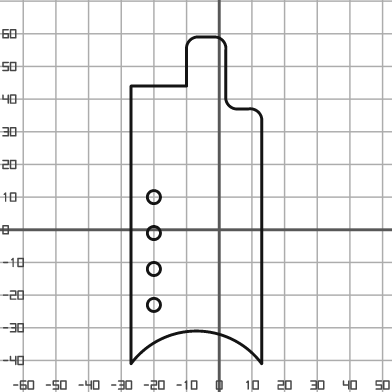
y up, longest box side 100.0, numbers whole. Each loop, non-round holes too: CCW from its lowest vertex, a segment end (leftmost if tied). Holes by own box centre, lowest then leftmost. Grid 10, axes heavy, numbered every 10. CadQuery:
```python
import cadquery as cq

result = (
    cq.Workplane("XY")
    .moveTo(-27.0, -41.0)
    .threePointArc((-7.0, -31.0), (13.0, -41.0))
    .lineTo(13.0, 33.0)
    .threePointArc((12.0, 36.0), (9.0, 37.0))
    .lineTo(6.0, 37.0)
    .threePointArc((3.0, 38.0), (2.0, 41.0))
    .lineTo(2.0, 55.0)
    .threePointArc((1.0, 58.0), (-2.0, 59.0))
    .lineTo(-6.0, 59.0)
    .threePointArc((-9.0, 58.0), (-10.0, 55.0))
    .lineTo(-10.0, 44.0)
    .lineTo(-27.0, 44.0)
    .close()
    .moveTo(-20.0, -23.0)
    .circle(2.0)
    .moveTo(-20.0, -12.0)
    .circle(2.0)
    .moveTo(-20.0, -1.0)
    .circle(2.0)
    .moveTo(-20.0, 10.0)
    .circle(2.0)
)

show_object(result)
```